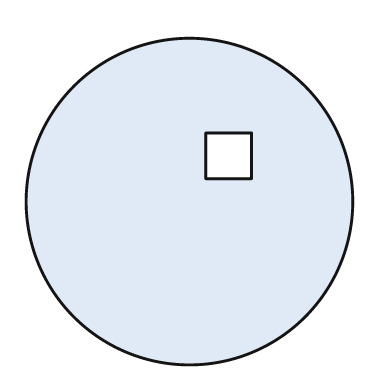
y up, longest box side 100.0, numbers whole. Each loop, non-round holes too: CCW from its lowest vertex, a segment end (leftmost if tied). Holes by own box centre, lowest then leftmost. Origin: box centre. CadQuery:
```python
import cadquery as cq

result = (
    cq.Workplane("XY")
    .moveTo(0.0, 0.0)
    .circle(50.0)
    .moveTo(5.0, 7.0)
    .lineTo(19.0, 7.0)
    .lineTo(19.0, 21.0)
    .lineTo(5.0, 21.0)
    .close()
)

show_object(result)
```